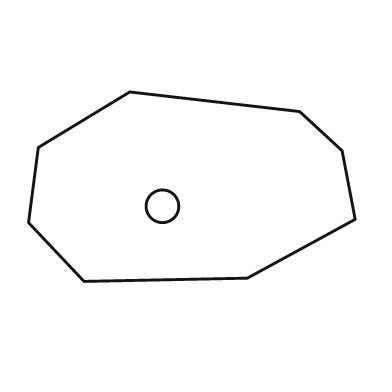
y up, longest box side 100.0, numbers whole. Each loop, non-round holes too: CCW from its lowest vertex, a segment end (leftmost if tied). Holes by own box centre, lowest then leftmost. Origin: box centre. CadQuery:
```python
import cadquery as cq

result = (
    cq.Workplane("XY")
    .moveTo(-33.0, -29.0)
    .lineTo(17.0, -28.0)
    .lineTo(50.0, -10.0)
    .lineTo(46.0, 11.0)
    .lineTo(33.0, 23.0)
    .lineTo(-19.0, 29.0)
    .lineTo(-47.0, 12.0)
    .lineTo(-50.0, -11.0)
    .close()
    .moveTo(-9.0, -6.0)
    .circle(5.0)
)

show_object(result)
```